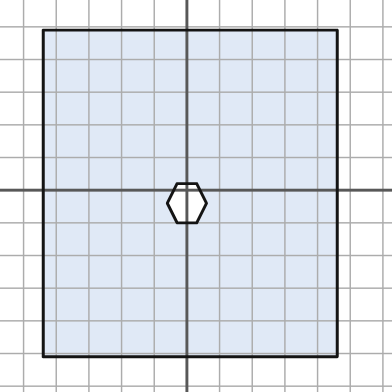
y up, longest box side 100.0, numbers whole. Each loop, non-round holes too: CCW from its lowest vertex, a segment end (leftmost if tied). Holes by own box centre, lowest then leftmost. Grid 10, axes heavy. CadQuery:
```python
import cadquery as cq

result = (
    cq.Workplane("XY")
    .moveTo(-44.0, -51.0)
    .lineTo(46.0, -51.0)
    .lineTo(46.0, 49.0)
    .lineTo(-44.0, 49.0)
    .close()
    .moveTo(-3.0, -10.0)
    .lineTo(3.0, -10.0)
    .lineTo(6.0, -4.0)
    .lineTo(3.0, 2.0)
    .lineTo(-3.0, 2.0)
    .lineTo(-6.0, -4.0)
    .close()
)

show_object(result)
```